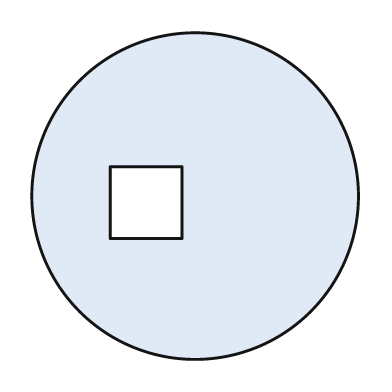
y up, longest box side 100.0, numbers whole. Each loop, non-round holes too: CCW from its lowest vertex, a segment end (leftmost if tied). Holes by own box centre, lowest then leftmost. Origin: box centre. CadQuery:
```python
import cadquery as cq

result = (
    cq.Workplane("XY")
    .moveTo(0.0, 0.0)
    .circle(50.0)
    .moveTo(-26.0, -13.0)
    .lineTo(-4.0, -13.0)
    .lineTo(-4.0, 9.0)
    .lineTo(-26.0, 9.0)
    .close()
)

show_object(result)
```